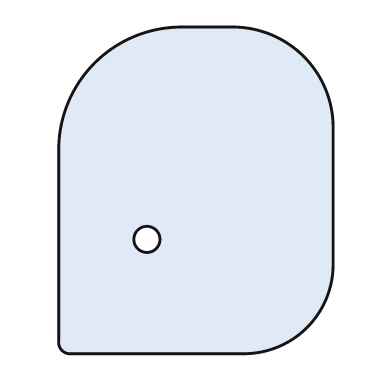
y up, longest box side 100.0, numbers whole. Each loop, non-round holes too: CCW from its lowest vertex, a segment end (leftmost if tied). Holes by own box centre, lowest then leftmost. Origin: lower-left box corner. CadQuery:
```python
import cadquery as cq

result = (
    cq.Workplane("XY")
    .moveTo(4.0, 0.0)
    .lineTo(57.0, 0.0)
    .threePointArc((76.0, 8.0), (84.0, 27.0))
    .lineTo(84.0, 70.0)
    .threePointArc((75.0, 91.0), (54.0, 100.0))
    .lineTo(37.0, 100.0)
    .threePointArc((11.0, 89.0), (0.0, 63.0))
    .lineTo(0.0, 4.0)
    .threePointArc((1.0, 1.0), (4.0, 0.0))
    .close()
    .moveTo(27.0, 35.0)
    .circle(4.0)
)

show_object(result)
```